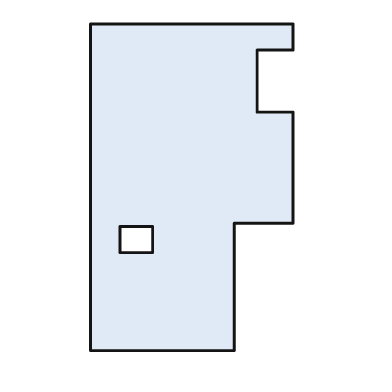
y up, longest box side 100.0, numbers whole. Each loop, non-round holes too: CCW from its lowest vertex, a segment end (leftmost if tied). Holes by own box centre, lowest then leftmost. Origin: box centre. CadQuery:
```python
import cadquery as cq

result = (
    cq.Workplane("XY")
    .moveTo(-31.0, -50.0)
    .lineTo(13.0, -50.0)
    .lineTo(13.0, -11.0)
    .lineTo(31.0, -11.0)
    .lineTo(31.0, 23.0)
    .lineTo(20.0, 23.0)
    .lineTo(20.0, 42.0)
    .lineTo(31.0, 42.0)
    .lineTo(31.0, 50.0)
    .lineTo(-31.0, 50.0)
    .close()
    .moveTo(-22.0, -20.0)
    .lineTo(-12.0, -20.0)
    .lineTo(-12.0, -12.0)
    .lineTo(-22.0, -12.0)
    .close()
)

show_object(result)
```